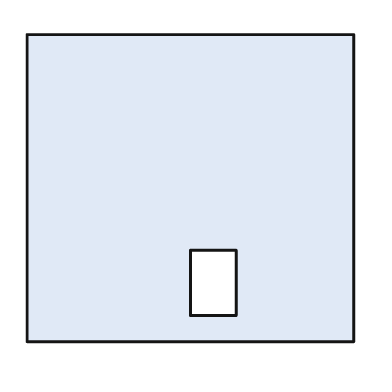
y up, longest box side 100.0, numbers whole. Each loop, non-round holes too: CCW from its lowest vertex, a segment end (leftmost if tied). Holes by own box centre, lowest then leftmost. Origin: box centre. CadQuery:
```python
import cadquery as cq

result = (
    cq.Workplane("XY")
    .moveTo(-50.0, -47.0)
    .lineTo(50.0, -47.0)
    .lineTo(50.0, 47.0)
    .lineTo(-50.0, 47.0)
    .close()
    .moveTo(0.0, -39.0)
    .lineTo(14.0, -39.0)
    .lineTo(14.0, -19.0)
    .lineTo(0.0, -19.0)
    .close()
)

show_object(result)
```